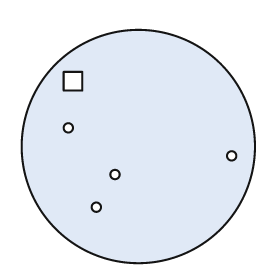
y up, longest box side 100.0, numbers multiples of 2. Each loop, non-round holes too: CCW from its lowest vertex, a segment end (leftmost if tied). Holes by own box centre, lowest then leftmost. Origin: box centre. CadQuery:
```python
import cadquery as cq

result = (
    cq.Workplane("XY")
    .moveTo(0.0, 0.0)
    .circle(50.0)
    .moveTo(-18.0, -26.0)
    .circle(2.0)
    .moveTo(-10.0, -12.0)
    .circle(2.0)
    .moveTo(40.0, -4.0)
    .circle(2.0)
    .moveTo(-30.0, 8.0)
    .circle(2.0)
    .moveTo(-32.0, 24.0)
    .lineTo(-24.0, 24.0)
    .lineTo(-24.0, 32.0)
    .lineTo(-32.0, 32.0)
    .close()
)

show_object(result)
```